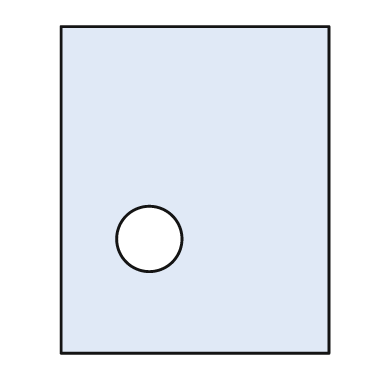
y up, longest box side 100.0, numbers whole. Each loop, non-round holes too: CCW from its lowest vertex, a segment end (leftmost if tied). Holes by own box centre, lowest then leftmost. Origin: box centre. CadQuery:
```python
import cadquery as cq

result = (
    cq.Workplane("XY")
    .moveTo(-41.0, -50.0)
    .lineTo(41.0, -50.0)
    .lineTo(41.0, 50.0)
    .lineTo(-41.0, 50.0)
    .close()
    .moveTo(-14.0, -15.0)
    .circle(10.0)
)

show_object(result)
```